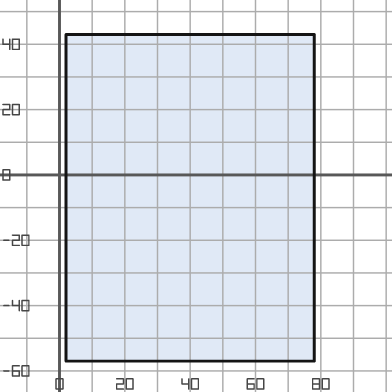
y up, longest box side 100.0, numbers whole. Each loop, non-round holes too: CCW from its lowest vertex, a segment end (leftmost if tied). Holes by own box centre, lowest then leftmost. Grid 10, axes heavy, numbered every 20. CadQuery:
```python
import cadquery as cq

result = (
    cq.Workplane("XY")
    .moveTo(2.0, -57.0)
    .lineTo(78.0, -57.0)
    .lineTo(78.0, 43.0)
    .lineTo(2.0, 43.0)
    .close()
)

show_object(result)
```